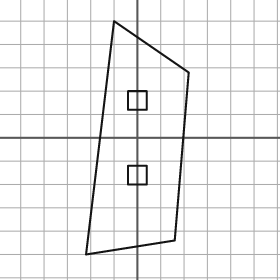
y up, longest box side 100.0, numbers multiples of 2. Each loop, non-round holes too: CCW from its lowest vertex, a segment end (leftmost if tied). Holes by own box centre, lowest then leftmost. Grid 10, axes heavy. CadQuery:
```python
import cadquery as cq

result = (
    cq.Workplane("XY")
    .moveTo(-22.0, -50.0)
    .lineTo(16.0, -44.0)
    .lineTo(22.0, 28.0)
    .lineTo(-10.0, 50.0)
    .close()
    .moveTo(-4.0, -20.0)
    .lineTo(4.0, -20.0)
    .lineTo(4.0, -12.0)
    .lineTo(-4.0, -12.0)
    .close()
    .moveTo(-4.0, 12.0)
    .lineTo(4.0, 12.0)
    .lineTo(4.0, 20.0)
    .lineTo(-4.0, 20.0)
    .close()
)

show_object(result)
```